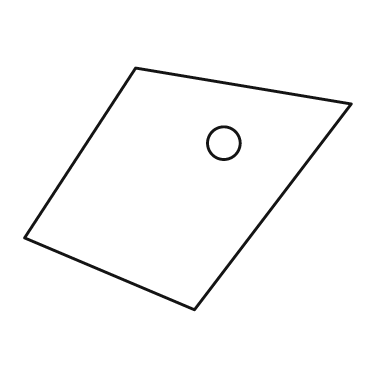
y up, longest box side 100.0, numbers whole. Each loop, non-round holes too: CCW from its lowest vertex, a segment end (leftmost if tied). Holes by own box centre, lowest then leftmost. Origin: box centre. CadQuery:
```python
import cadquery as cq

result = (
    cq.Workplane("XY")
    .moveTo(2.0, -37.0)
    .lineTo(50.0, 26.0)
    .lineTo(-16.0, 37.0)
    .lineTo(-50.0, -15.0)
    .close()
    .moveTo(11.0, 14.0)
    .circle(5.0)
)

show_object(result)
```